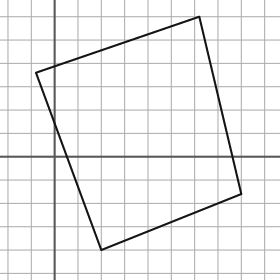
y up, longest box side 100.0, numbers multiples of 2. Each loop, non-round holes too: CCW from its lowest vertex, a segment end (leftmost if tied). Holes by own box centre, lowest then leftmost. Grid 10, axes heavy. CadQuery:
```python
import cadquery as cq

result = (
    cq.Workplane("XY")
    .moveTo(20.0, -40.0)
    .lineTo(80.0, -16.0)
    .lineTo(62.0, 60.0)
    .lineTo(-8.0, 36.0)
    .close()
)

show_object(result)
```